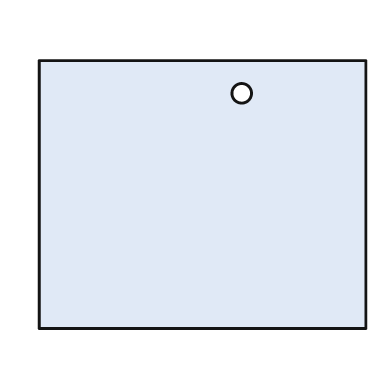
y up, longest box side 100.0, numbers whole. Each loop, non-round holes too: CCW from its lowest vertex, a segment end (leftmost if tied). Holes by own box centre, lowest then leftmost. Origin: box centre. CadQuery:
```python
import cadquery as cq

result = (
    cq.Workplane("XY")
    .moveTo(-50.0, -41.0)
    .lineTo(50.0, -41.0)
    .lineTo(50.0, 41.0)
    .lineTo(-50.0, 41.0)
    .close()
    .moveTo(12.0, 31.0)
    .circle(3.0)
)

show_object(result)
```